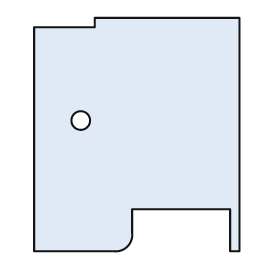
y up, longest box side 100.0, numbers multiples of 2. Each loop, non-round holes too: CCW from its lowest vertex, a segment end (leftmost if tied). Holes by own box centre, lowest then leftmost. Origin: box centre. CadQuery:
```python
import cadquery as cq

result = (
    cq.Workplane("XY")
    .moveTo(-44.0, -50.0)
    .lineTo(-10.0, -50.0)
    .threePointArc((-4.0, -48.0), (-2.0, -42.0))
    .lineTo(-2.0, -32.0)
    .lineTo(40.0, -32.0)
    .lineTo(40.0, -50.0)
    .lineTo(44.0, -50.0)
    .lineTo(44.0, 50.0)
    .lineTo(-18.0, 50.0)
    .lineTo(-18.0, 46.0)
    .lineTo(-44.0, 46.0)
    .close()
    .moveTo(-24.0, 6.0)
    .circle(4.0)
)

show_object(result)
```